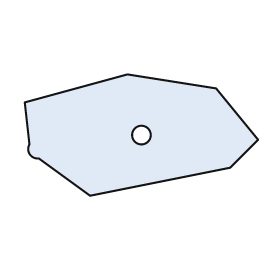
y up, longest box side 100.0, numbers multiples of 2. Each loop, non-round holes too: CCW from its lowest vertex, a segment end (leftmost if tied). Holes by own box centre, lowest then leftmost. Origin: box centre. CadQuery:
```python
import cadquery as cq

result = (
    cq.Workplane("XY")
    .moveTo(-22.0, -26.0)
    .lineTo(38.0, -14.0)
    .lineTo(50.0, -2.0)
    .lineTo(32.0, 20.0)
    .lineTo(-6.0, 26.0)
    .lineTo(-50.0, 14.0)
    .lineTo(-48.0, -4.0)
    .threePointArc((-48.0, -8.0), (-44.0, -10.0))
    .close()
    .moveTo(0.0, 0.0)
    .circle(4.0)
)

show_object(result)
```